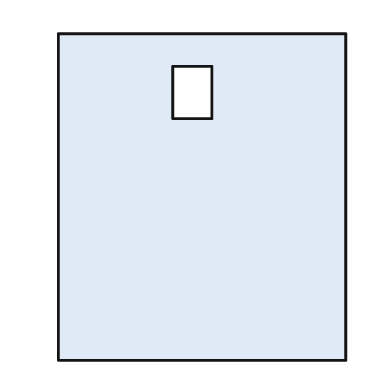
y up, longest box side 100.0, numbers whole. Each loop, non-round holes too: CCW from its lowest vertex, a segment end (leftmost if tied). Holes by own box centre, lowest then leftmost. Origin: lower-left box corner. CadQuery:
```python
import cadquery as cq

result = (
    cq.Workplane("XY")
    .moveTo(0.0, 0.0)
    .lineTo(88.0, 0.0)
    .lineTo(88.0, 100.0)
    .lineTo(0.0, 100.0)
    .close()
    .moveTo(35.0, 74.0)
    .lineTo(47.0, 74.0)
    .lineTo(47.0, 90.0)
    .lineTo(35.0, 90.0)
    .close()
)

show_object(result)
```